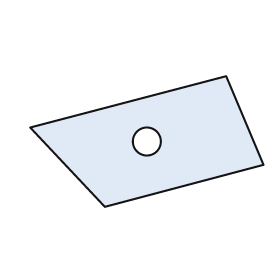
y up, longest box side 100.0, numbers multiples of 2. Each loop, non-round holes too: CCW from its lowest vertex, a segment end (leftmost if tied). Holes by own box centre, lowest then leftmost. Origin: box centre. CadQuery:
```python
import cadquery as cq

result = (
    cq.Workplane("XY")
    .moveTo(-18.0, -28.0)
    .lineTo(50.0, -10.0)
    .lineTo(34.0, 28.0)
    .lineTo(-50.0, 6.0)
    .close()
    .moveTo(0.0, 0.0)
    .circle(6.0)
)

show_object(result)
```